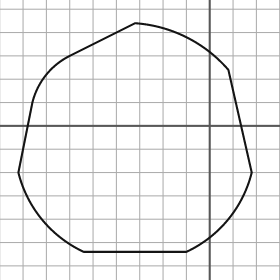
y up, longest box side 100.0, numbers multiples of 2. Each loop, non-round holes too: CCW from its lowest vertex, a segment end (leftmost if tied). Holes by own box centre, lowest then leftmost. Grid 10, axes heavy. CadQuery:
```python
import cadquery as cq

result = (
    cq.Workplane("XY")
    .moveTo(-54.0, -54.0)
    .lineTo(-10.0, -54.0)
    .threePointArc((8.0, -40.0), (18.0, -20.0))
    .lineTo(8.0, 24.0)
    .threePointArc((-10.0, 38.0), (-32.0, 44.0))
    .lineTo(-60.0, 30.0)
    .threePointArc((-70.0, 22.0), (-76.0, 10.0))
    .lineTo(-82.0, -20.0)
    .threePointArc((-72.0, -40.0), (-54.0, -54.0))
    .close()
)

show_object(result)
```